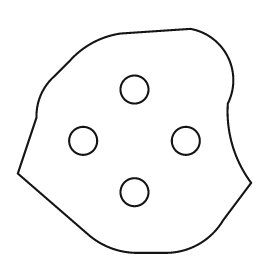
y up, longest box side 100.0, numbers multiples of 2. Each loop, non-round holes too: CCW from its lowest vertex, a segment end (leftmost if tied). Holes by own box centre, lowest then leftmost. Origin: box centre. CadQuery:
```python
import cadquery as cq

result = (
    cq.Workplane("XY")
    .moveTo(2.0, -48.0)
    .lineTo(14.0, -48.0)
    .threePointArc((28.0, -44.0), (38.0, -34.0))
    .lineTo(50.0, -18.0)
    .threePointArc((42.0, -2.0), (40.0, 16.0))
    .threePointArc((40.0, 36.0), (24.0, 48.0))
    .lineTo(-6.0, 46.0)
    .threePointArc((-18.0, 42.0), (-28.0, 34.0))
    .lineTo(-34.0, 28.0)
    .threePointArc((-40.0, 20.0), (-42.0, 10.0))
    .lineTo(-50.0, -14.0)
    .lineTo(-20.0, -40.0)
    .threePointArc((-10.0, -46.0), (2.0, -48.0))
    .close()
    .moveTo(0.0, -22.0)
    .circle(6.0)
    .moveTo(-22.0, 0.0)
    .circle(6.0)
    .moveTo(22.0, 0.0)
    .circle(6.0)
    .moveTo(0.0, 22.0)
    .circle(6.0)
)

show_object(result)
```